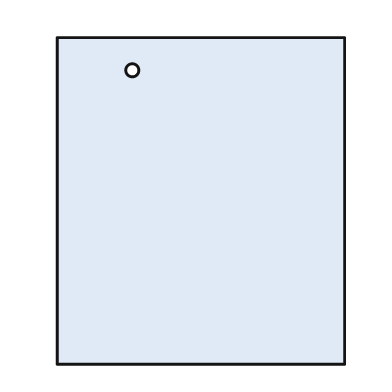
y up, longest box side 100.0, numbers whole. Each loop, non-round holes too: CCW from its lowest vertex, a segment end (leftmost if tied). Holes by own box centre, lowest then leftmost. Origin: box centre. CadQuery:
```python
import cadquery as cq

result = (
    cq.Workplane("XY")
    .moveTo(-44.0, -50.0)
    .lineTo(44.0, -50.0)
    .lineTo(44.0, 50.0)
    .lineTo(-44.0, 50.0)
    .close()
    .moveTo(-21.0, 40.0)
    .circle(2.0)
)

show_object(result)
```